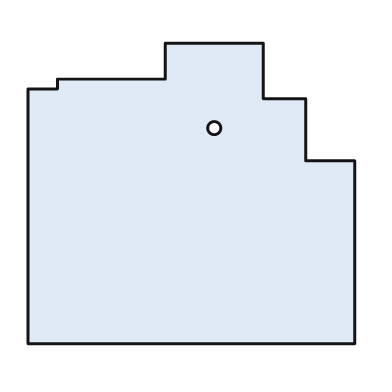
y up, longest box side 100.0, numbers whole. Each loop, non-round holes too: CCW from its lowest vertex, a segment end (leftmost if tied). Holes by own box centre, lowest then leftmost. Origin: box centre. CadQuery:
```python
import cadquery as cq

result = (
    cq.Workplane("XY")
    .moveTo(-50.0, -46.0)
    .lineTo(50.0, -46.0)
    .lineTo(50.0, 10.0)
    .lineTo(35.0, 10.0)
    .lineTo(35.0, 29.0)
    .lineTo(22.0, 29.0)
    .lineTo(22.0, 46.0)
    .lineTo(-8.0, 46.0)
    .lineTo(-8.0, 35.0)
    .lineTo(-41.0, 35.0)
    .lineTo(-41.0, 32.0)
    .lineTo(-50.0, 32.0)
    .close()
    .moveTo(7.0, 20.0)
    .circle(2.0)
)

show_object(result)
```